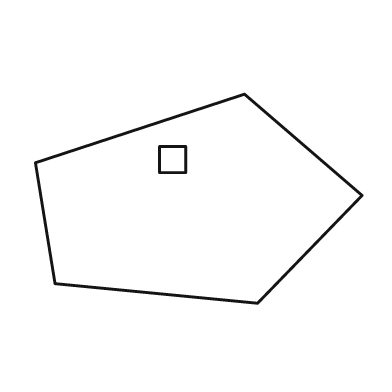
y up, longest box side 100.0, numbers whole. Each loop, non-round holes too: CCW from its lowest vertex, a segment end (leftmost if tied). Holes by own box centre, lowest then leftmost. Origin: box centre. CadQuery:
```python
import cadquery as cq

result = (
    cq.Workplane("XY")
    .moveTo(18.0, -32.0)
    .lineTo(50.0, 1.0)
    .lineTo(14.0, 32.0)
    .lineTo(-50.0, 11.0)
    .lineTo(-44.0, -26.0)
    .close()
    .moveTo(-12.0, 8.0)
    .lineTo(-4.0, 8.0)
    .lineTo(-4.0, 16.0)
    .lineTo(-12.0, 16.0)
    .close()
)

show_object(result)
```